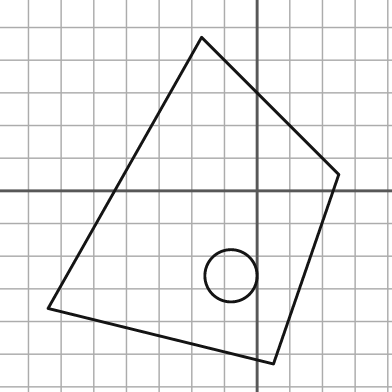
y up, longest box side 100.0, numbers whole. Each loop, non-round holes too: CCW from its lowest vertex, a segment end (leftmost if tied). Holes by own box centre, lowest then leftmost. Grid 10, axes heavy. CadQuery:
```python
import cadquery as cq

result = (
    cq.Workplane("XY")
    .moveTo(5.0, -53.0)
    .lineTo(25.0, 5.0)
    .lineTo(-17.0, 47.0)
    .lineTo(-64.0, -36.0)
    .close()
    .moveTo(-8.0, -26.0)
    .circle(8.0)
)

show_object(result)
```